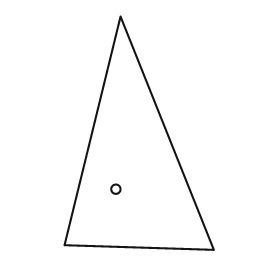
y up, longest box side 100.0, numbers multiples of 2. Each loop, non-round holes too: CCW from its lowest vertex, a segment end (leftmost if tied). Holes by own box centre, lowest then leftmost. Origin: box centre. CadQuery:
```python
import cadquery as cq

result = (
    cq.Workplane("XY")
    .moveTo(32.0, -50.0)
    .lineTo(-8.0, 50.0)
    .lineTo(-32.0, -48.0)
    .close()
    .moveTo(-10.0, -24.0)
    .circle(2.0)
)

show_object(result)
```